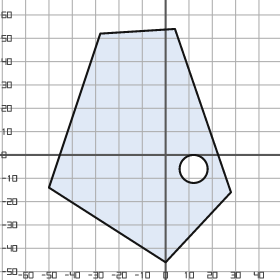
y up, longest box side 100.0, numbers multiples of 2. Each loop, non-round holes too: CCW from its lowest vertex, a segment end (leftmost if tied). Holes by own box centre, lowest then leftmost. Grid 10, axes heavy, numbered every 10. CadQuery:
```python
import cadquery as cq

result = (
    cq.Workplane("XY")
    .moveTo(0.0, -46.0)
    .lineTo(28.0, -16.0)
    .lineTo(4.0, 54.0)
    .lineTo(-28.0, 52.0)
    .lineTo(-50.0, -14.0)
    .close()
    .moveTo(12.0, -6.0)
    .circle(6.0)
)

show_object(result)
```